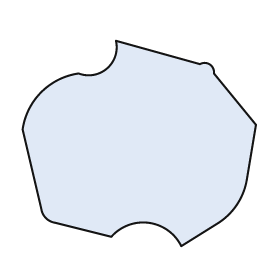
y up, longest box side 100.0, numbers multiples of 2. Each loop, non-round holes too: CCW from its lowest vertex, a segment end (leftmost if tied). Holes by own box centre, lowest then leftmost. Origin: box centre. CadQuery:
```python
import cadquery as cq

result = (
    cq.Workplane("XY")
    .moveTo(18.0, -44.0)
    .lineTo(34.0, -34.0)
    .threePointArc((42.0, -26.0), (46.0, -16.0))
    .lineTo(50.0, 8.0)
    .lineTo(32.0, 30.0)
    .threePointArc((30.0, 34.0), (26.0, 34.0))
    .lineTo(-10.0, 44.0)
    .threePointArc((-14.0, 32.0), (-26.0, 30.0))
    .threePointArc((-42.0, 22.0), (-50.0, 6.0))
    .lineTo(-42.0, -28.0)
    .threePointArc((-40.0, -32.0), (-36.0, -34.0))
    .lineTo(-12.0, -40.0)
    .threePointArc((4.0, -34.0), (18.0, -44.0))
    .close()
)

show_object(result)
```